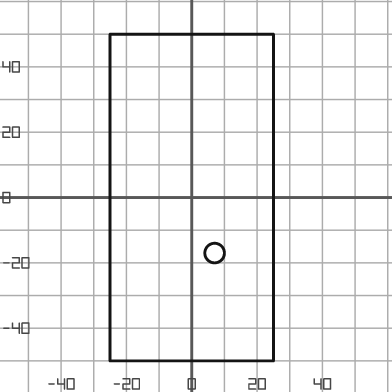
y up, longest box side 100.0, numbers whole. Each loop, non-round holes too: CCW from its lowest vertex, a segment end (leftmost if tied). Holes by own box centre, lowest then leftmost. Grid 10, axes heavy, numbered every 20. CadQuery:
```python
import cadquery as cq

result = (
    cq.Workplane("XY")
    .moveTo(-25.0, -50.0)
    .lineTo(25.0, -50.0)
    .lineTo(25.0, 50.0)
    .lineTo(-25.0, 50.0)
    .close()
    .moveTo(7.0, -17.0)
    .circle(3.0)
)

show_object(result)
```